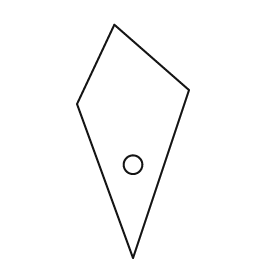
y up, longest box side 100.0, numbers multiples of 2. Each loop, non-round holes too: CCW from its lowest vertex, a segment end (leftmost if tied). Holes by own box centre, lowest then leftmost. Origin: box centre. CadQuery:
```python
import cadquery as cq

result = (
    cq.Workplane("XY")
    .moveTo(0.0, -50.0)
    .lineTo(24.0, 22.0)
    .lineTo(-8.0, 50.0)
    .lineTo(-24.0, 16.0)
    .close()
    .moveTo(0.0, -10.0)
    .circle(4.0)
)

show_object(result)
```